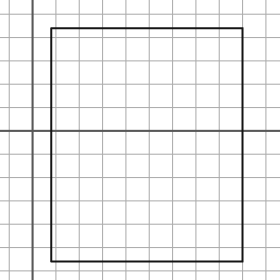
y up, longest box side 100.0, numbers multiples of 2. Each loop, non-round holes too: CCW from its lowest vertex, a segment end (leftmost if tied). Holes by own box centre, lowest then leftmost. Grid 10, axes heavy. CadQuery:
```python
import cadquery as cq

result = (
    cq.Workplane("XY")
    .moveTo(8.0, -56.0)
    .lineTo(90.0, -56.0)
    .lineTo(90.0, 44.0)
    .lineTo(8.0, 44.0)
    .close()
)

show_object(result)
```